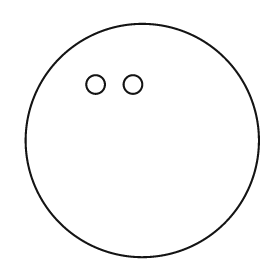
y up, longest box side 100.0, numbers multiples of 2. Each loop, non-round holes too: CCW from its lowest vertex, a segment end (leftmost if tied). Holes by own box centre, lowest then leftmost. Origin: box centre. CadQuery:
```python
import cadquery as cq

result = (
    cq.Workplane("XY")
    .moveTo(0.0, 0.0)
    .circle(50.0)
    .moveTo(-20.0, 24.0)
    .circle(4.0)
    .moveTo(-4.0, 24.0)
    .circle(4.0)
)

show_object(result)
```